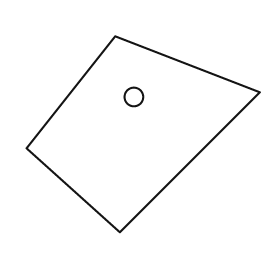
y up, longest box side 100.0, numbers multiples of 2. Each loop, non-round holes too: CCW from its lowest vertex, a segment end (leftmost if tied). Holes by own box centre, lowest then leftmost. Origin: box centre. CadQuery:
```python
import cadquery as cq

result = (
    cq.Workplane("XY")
    .moveTo(-10.0, -42.0)
    .lineTo(50.0, 18.0)
    .lineTo(-12.0, 42.0)
    .lineTo(-50.0, -6.0)
    .close()
    .moveTo(-4.0, 16.0)
    .circle(4.0)
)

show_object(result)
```